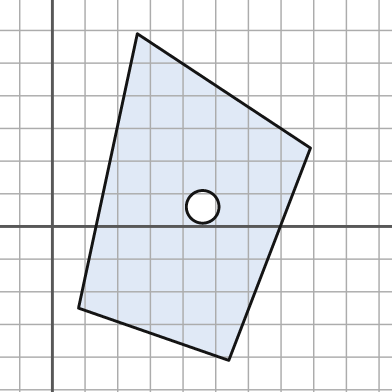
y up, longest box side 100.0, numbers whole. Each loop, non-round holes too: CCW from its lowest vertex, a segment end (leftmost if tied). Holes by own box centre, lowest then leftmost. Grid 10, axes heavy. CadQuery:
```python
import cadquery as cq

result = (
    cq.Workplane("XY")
    .moveTo(54.0, -41.0)
    .lineTo(79.0, 24.0)
    .lineTo(26.0, 59.0)
    .lineTo(8.0, -25.0)
    .close()
    .moveTo(46.0, 6.0)
    .circle(5.0)
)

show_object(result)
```